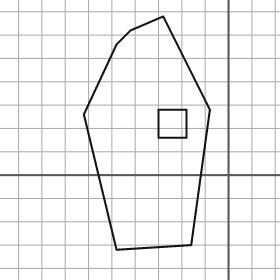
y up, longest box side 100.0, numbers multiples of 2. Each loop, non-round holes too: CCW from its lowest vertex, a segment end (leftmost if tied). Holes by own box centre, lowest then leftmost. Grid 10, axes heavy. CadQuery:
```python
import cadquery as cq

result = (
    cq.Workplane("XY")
    .moveTo(-48.0, -32.0)
    .lineTo(-16.0, -30.0)
    .lineTo(-8.0, 28.0)
    .lineTo(-28.0, 68.0)
    .lineTo(-42.0, 62.0)
    .lineTo(-48.0, 56.0)
    .lineTo(-62.0, 26.0)
    .close()
    .moveTo(-30.0, 16.0)
    .lineTo(-18.0, 16.0)
    .lineTo(-18.0, 28.0)
    .lineTo(-30.0, 28.0)
    .close()
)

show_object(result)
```